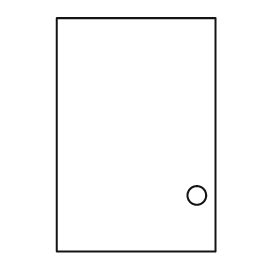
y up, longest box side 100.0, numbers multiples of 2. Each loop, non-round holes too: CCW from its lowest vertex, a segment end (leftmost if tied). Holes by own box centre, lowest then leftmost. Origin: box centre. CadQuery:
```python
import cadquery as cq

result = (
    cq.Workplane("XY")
    .moveTo(-34.0, -50.0)
    .lineTo(34.0, -50.0)
    .lineTo(34.0, 50.0)
    .lineTo(-34.0, 50.0)
    .close()
    .moveTo(26.0, -26.0)
    .circle(4.0)
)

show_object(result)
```